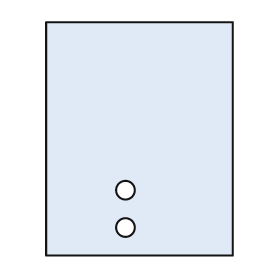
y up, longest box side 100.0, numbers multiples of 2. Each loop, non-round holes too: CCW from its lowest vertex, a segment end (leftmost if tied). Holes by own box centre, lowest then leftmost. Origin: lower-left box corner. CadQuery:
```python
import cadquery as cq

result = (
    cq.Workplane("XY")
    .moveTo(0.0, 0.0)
    .lineTo(80.0, 0.0)
    .lineTo(80.0, 100.0)
    .lineTo(0.0, 100.0)
    .close()
    .moveTo(34.0, 12.0)
    .circle(4.0)
    .moveTo(34.0, 28.0)
    .circle(4.0)
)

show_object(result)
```